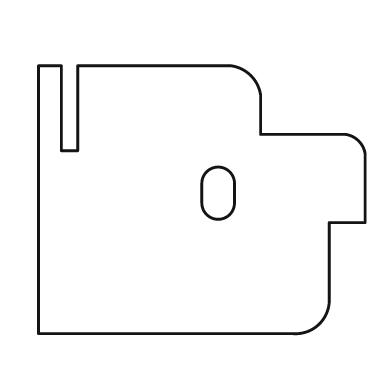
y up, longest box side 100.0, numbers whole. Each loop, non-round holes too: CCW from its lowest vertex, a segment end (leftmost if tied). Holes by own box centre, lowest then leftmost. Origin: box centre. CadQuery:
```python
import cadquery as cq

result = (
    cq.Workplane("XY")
    .moveTo(-50.0, -41.0)
    .lineTo(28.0, -41.0)
    .threePointArc((36.0, -38.0), (39.0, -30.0))
    .lineTo(39.0, -7.0)
    .lineTo(50.0, -7.0)
    .lineTo(50.0, 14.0)
    .threePointArc((48.0, 18.0), (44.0, 20.0))
    .lineTo(18.0, 20.0)
    .lineTo(18.0, 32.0)
    .threePointArc((15.0, 38.0), (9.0, 41.0))
    .lineTo(-38.0, 41.0)
    .lineTo(-38.0, 15.0)
    .lineTo(-43.0, 15.0)
    .lineTo(-43.0, 41.0)
    .lineTo(-50.0, 41.0)
    .close()
    .moveTo(0.0, -1.0)
    .threePointArc((5.0, -6.0), (10.0, -1.0))
    .lineTo(10.0, 5.0)
    .threePointArc((5.0, 10.0), (0.0, 5.0))
    .close()
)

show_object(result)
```